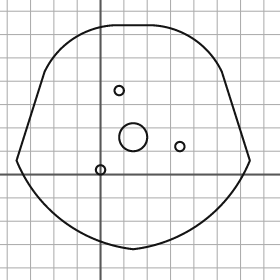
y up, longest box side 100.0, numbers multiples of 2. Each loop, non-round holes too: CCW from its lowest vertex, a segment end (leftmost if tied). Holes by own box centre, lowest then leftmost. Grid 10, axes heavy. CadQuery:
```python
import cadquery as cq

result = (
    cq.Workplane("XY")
    .moveTo(14.0, -32.0)
    .threePointArc((44.0, -20.0), (64.0, 6.0))
    .lineTo(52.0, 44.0)
    .threePointArc((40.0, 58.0), (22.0, 64.0))
    .lineTo(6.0, 64.0)
    .threePointArc((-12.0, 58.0), (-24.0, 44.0))
    .lineTo(-36.0, 6.0)
    .threePointArc((-16.0, -20.0), (14.0, -32.0))
    .close()
    .moveTo(0.0, 2.0)
    .circle(2.0)
    .moveTo(34.0, 12.0)
    .circle(2.0)
    .moveTo(14.0, 16.0)
    .circle(6.0)
    .moveTo(8.0, 36.0)
    .circle(2.0)
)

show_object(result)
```